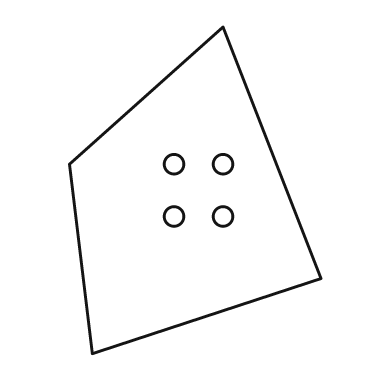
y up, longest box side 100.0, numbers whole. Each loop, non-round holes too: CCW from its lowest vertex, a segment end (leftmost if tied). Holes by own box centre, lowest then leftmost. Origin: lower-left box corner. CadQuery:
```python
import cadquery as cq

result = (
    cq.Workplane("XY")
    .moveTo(7.0, 0.0)
    .lineTo(77.0, 23.0)
    .lineTo(47.0, 100.0)
    .lineTo(0.0, 58.0)
    .close()
    .moveTo(32.0, 42.0)
    .circle(3.0)
    .moveTo(47.0, 42.0)
    .circle(3.0)
    .moveTo(32.0, 58.0)
    .circle(3.0)
    .moveTo(47.0, 58.0)
    .circle(3.0)
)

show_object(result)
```